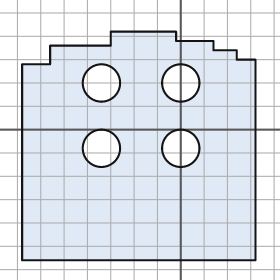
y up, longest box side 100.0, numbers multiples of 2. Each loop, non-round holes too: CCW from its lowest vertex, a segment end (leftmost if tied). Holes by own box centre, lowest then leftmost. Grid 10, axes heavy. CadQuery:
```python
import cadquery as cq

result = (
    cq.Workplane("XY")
    .moveTo(-68.0, -56.0)
    .lineTo(32.0, -56.0)
    .lineTo(32.0, 30.0)
    .lineTo(24.0, 30.0)
    .lineTo(24.0, 34.0)
    .lineTo(14.0, 34.0)
    .lineTo(14.0, 38.0)
    .lineTo(-2.0, 38.0)
    .lineTo(-2.0, 42.0)
    .lineTo(-30.0, 42.0)
    .lineTo(-30.0, 36.0)
    .lineTo(-56.0, 36.0)
    .lineTo(-56.0, 28.0)
    .lineTo(-68.0, 28.0)
    .close()
    .moveTo(-34.0, -8.0)
    .circle(8.0)
    .moveTo(0.0, -8.0)
    .circle(8.0)
    .moveTo(-34.0, 20.0)
    .circle(8.0)
    .moveTo(0.0, 20.0)
    .circle(8.0)
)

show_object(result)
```